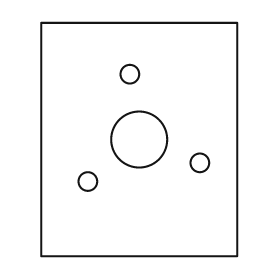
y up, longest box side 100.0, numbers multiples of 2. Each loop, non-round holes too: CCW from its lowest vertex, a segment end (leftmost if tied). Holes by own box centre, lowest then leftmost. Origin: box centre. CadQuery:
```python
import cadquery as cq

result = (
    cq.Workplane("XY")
    .moveTo(-42.0, -50.0)
    .lineTo(42.0, -50.0)
    .lineTo(42.0, 50.0)
    .lineTo(-42.0, 50.0)
    .close()
    .moveTo(-22.0, -18.0)
    .circle(4.0)
    .moveTo(26.0, -10.0)
    .circle(4.0)
    .moveTo(0.0, 0.0)
    .circle(12.0)
    .moveTo(-4.0, 28.0)
    .circle(4.0)
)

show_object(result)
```